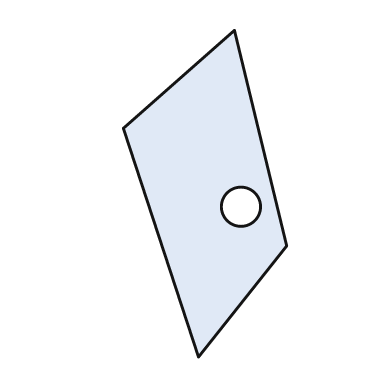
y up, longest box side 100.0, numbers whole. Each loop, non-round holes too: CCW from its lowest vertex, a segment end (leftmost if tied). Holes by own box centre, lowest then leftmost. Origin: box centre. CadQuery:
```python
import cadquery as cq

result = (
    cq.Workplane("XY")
    .moveTo(-2.0, -50.0)
    .lineTo(25.0, -16.0)
    .lineTo(9.0, 50.0)
    .lineTo(-25.0, 20.0)
    .close()
    .moveTo(11.0, -4.0)
    .circle(6.0)
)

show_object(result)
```